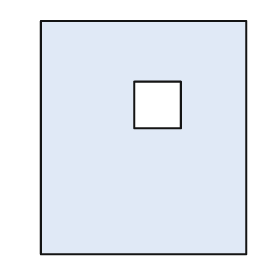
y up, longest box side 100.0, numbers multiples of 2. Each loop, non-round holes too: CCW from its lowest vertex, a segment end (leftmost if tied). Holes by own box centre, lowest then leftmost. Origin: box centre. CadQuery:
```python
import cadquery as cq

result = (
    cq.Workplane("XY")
    .moveTo(-44.0, -50.0)
    .lineTo(44.0, -50.0)
    .lineTo(44.0, 50.0)
    .lineTo(-44.0, 50.0)
    .close()
    .moveTo(-4.0, 4.0)
    .lineTo(16.0, 4.0)
    .lineTo(16.0, 24.0)
    .lineTo(-4.0, 24.0)
    .close()
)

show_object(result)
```